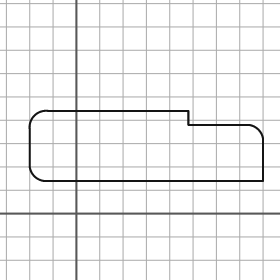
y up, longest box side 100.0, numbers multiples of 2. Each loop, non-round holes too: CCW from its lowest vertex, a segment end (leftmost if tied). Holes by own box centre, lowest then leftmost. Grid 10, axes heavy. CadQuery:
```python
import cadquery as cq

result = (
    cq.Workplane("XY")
    .moveTo(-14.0, 14.0)
    .lineTo(80.0, 14.0)
    .lineTo(80.0, 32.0)
    .threePointArc((78.0, 36.0), (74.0, 38.0))
    .lineTo(48.0, 38.0)
    .lineTo(48.0, 44.0)
    .lineTo(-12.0, 44.0)
    .threePointArc((-18.0, 42.0), (-20.0, 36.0))
    .lineTo(-20.0, 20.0)
    .threePointArc((-18.0, 16.0), (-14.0, 14.0))
    .close()
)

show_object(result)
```